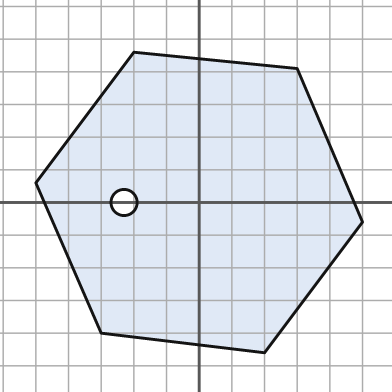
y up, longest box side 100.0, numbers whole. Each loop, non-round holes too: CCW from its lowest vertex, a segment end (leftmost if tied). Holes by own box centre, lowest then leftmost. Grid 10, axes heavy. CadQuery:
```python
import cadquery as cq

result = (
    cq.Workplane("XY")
    .moveTo(20.0, -46.0)
    .lineTo(50.0, -6.0)
    .lineTo(30.0, 41.0)
    .lineTo(-20.0, 46.0)
    .lineTo(-50.0, 6.0)
    .lineTo(-30.0, -40.0)
    .close()
    .moveTo(-23.0, 0.0)
    .circle(4.0)
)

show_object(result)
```